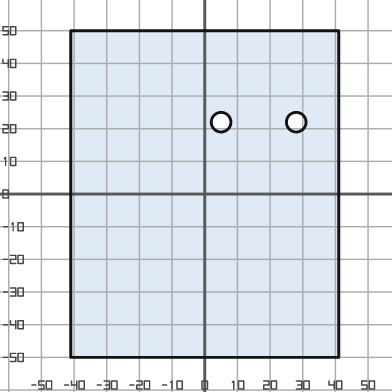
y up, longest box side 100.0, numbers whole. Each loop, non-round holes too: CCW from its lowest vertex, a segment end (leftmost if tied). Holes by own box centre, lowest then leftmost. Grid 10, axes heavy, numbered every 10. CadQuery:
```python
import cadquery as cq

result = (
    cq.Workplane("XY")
    .moveTo(-41.0, -50.0)
    .lineTo(41.0, -50.0)
    .lineTo(41.0, 50.0)
    .lineTo(-41.0, 50.0)
    .close()
    .moveTo(5.0, 22.0)
    .circle(3.0)
    .moveTo(28.0, 22.0)
    .circle(3.0)
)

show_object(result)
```